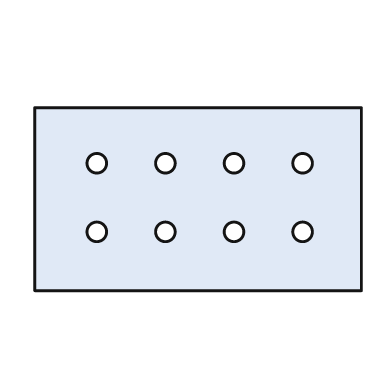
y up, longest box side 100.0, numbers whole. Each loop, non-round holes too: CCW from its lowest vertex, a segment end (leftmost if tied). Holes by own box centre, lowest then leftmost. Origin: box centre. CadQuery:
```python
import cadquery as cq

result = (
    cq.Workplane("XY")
    .moveTo(-50.0, -28.0)
    .lineTo(50.0, -28.0)
    .lineTo(50.0, 28.0)
    .lineTo(-50.0, 28.0)
    .close()
    .moveTo(-31.0, -10.0)
    .circle(3.0)
    .moveTo(-10.0, -10.0)
    .circle(3.0)
    .moveTo(11.0, -10.0)
    .circle(3.0)
    .moveTo(32.0, -10.0)
    .circle(3.0)
    .moveTo(-31.0, 11.0)
    .circle(3.0)
    .moveTo(-10.0, 11.0)
    .circle(3.0)
    .moveTo(11.0, 11.0)
    .circle(3.0)
    .moveTo(32.0, 11.0)
    .circle(3.0)
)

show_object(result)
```